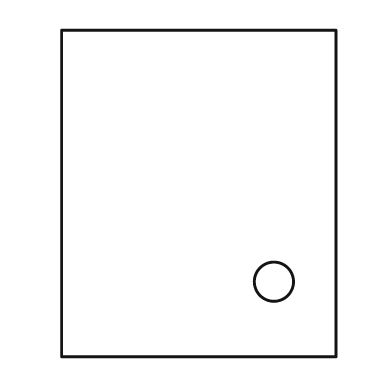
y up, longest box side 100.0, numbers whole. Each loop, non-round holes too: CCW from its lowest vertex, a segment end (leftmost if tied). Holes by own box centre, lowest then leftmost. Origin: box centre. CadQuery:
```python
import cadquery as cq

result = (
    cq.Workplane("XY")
    .moveTo(-42.0, -50.0)
    .lineTo(42.0, -50.0)
    .lineTo(42.0, 50.0)
    .lineTo(-42.0, 50.0)
    .close()
    .moveTo(23.0, -27.0)
    .circle(6.0)
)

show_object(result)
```